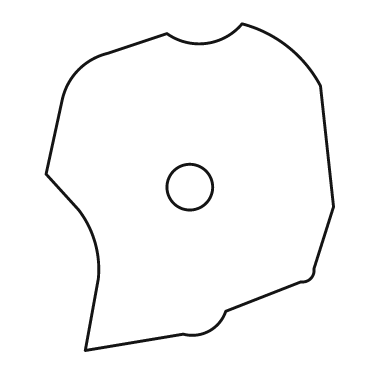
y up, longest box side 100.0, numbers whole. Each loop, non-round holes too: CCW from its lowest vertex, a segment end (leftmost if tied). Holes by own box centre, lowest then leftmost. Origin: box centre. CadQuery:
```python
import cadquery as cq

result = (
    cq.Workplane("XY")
    .moveTo(-32.0, -50.0)
    .lineTo(-2.0, -45.0)
    .threePointArc((6.0, -44.0), (11.0, -38.0))
    .lineTo(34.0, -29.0)
    .threePointArc((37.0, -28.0), (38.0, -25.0))
    .lineTo(44.0, -6.0)
    .lineTo(40.0, 31.0)
    .threePointArc((30.0, 43.0), (16.0, 50.0))
    .threePointArc((5.0, 44.0), (-7.0, 47.0))
    .lineTo(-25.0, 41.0)
    .threePointArc((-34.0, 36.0), (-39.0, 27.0))
    .lineTo(-44.0, 4.0)
    .lineTo(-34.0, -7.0)
    .threePointArc((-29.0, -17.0), (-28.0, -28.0))
    .close()
    .moveTo(0.0, 0.0)
    .circle(7.0)
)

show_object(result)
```